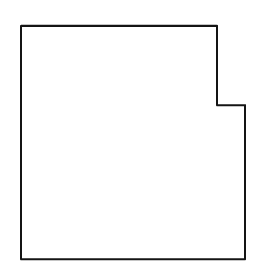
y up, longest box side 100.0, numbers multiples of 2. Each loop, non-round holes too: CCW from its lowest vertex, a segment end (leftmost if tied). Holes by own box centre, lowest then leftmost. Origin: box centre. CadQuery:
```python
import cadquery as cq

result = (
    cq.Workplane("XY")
    .moveTo(-48.0, -50.0)
    .lineTo(48.0, -50.0)
    .lineTo(48.0, 16.0)
    .lineTo(36.0, 16.0)
    .lineTo(36.0, 50.0)
    .lineTo(-48.0, 50.0)
    .close()
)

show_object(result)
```